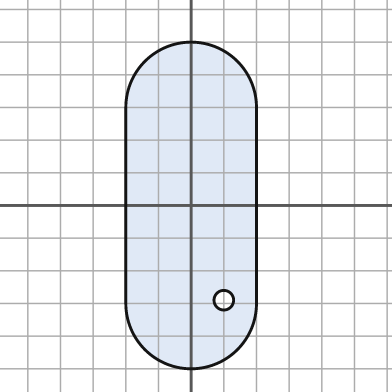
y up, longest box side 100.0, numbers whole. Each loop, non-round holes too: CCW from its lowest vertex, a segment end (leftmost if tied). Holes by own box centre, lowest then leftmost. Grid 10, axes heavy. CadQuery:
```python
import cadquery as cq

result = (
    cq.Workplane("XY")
    .moveTo(-20.0, -30.0)
    .threePointArc((0.0, -50.0), (20.0, -30.0))
    .lineTo(20.0, 30.0)
    .threePointArc((0.0, 50.0), (-20.0, 30.0))
    .close()
    .moveTo(10.0, -29.0)
    .circle(3.0)
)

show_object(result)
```